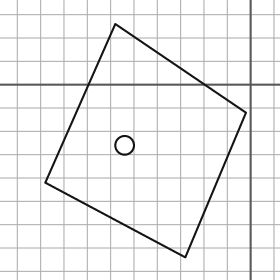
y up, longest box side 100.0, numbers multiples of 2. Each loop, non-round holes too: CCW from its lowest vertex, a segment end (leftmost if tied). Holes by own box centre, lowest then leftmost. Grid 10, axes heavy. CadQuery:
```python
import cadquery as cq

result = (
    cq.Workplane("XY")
    .moveTo(-28.0, -74.0)
    .lineTo(-2.0, -12.0)
    .lineTo(-58.0, 26.0)
    .lineTo(-88.0, -42.0)
    .close()
    .moveTo(-54.0, -26.0)
    .circle(4.0)
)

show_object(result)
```